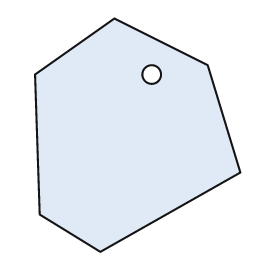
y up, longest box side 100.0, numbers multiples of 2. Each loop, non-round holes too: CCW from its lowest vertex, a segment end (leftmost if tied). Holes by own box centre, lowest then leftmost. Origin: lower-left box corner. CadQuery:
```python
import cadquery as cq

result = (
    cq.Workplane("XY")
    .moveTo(28.0, 0.0)
    .lineTo(88.0, 34.0)
    .lineTo(74.0, 80.0)
    .lineTo(34.0, 100.0)
    .lineTo(0.0, 76.0)
    .lineTo(2.0, 16.0)
    .close()
    .moveTo(50.0, 76.0)
    .circle(4.0)
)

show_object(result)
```